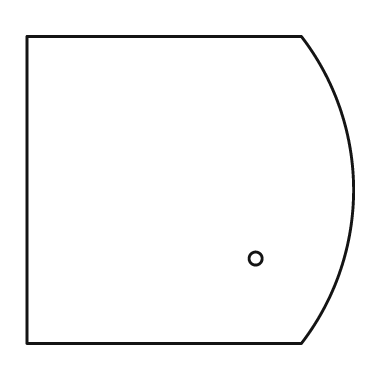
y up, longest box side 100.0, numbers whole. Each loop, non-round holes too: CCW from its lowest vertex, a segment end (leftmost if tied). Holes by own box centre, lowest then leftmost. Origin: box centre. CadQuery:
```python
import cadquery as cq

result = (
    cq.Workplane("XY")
    .moveTo(-50.0, -47.0)
    .lineTo(34.0, -47.0)
    .threePointArc((50.0, 0.0), (34.0, 47.0))
    .lineTo(-50.0, 47.0)
    .close()
    .moveTo(20.0, -21.0)
    .circle(2.0)
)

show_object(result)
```